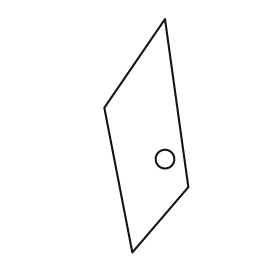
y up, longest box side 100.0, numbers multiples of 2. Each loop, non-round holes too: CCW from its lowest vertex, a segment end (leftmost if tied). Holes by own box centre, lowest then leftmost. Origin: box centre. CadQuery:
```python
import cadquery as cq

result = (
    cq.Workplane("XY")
    .moveTo(-6.0, -50.0)
    .lineTo(18.0, -22.0)
    .lineTo(8.0, 50.0)
    .lineTo(-18.0, 12.0)
    .close()
    .moveTo(8.0, -10.0)
    .circle(4.0)
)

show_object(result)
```